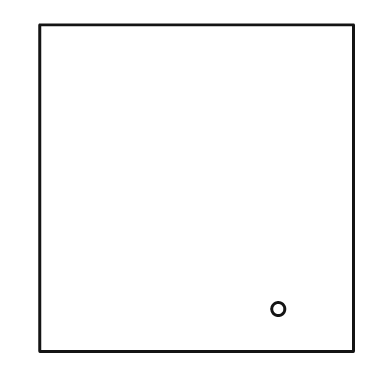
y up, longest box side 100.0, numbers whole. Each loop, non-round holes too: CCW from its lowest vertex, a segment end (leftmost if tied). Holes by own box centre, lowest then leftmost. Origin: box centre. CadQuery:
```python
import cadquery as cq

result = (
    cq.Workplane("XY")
    .moveTo(-48.0, -50.0)
    .lineTo(48.0, -50.0)
    .lineTo(48.0, 50.0)
    .lineTo(-48.0, 50.0)
    .close()
    .moveTo(25.0, -37.0)
    .circle(2.0)
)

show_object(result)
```